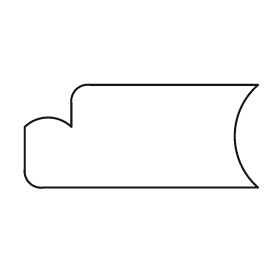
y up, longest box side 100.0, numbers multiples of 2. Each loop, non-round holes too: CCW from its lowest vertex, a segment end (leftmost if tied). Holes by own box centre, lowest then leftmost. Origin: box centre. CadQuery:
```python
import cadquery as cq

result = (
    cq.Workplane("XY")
    .moveTo(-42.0, -22.0)
    .lineTo(50.0, -22.0)
    .threePointArc((40.0, 0.0), (50.0, 22.0))
    .lineTo(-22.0, 22.0)
    .threePointArc((-28.0, 20.0), (-30.0, 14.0))
    .lineTo(-30.0, 4.0)
    .threePointArc((-40.0, 8.0), (-50.0, 4.0))
    .lineTo(-50.0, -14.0)
    .threePointArc((-48.0, -20.0), (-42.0, -22.0))
    .close()
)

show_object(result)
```